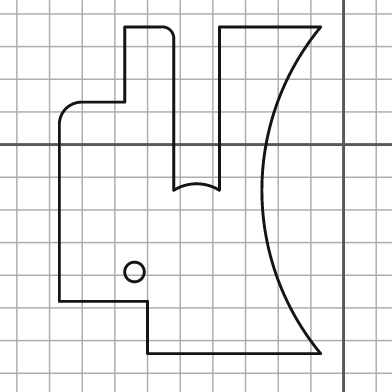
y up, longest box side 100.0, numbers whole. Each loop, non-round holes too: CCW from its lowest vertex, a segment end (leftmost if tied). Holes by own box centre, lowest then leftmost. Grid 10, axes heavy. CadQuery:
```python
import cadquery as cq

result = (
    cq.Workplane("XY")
    .moveTo(-60.0, -64.0)
    .lineTo(-7.0, -64.0)
    .threePointArc((-25.0, -14.0), (-7.0, 36.0))
    .lineTo(-38.0, 36.0)
    .lineTo(-38.0, -14.0)
    .threePointArc((-45.0, -12.0), (-52.0, -14.0))
    .lineTo(-52.0, 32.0)
    .threePointArc((-53.0, 35.0), (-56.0, 36.0))
    .lineTo(-67.0, 36.0)
    .lineTo(-67.0, 13.0)
    .lineTo(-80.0, 13.0)
    .threePointArc((-85.0, 11.0), (-87.0, 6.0))
    .lineTo(-87.0, -48.0)
    .lineTo(-60.0, -48.0)
    .close()
    .moveTo(-64.0, -39.0)
    .circle(3.0)
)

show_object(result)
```